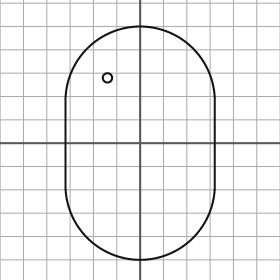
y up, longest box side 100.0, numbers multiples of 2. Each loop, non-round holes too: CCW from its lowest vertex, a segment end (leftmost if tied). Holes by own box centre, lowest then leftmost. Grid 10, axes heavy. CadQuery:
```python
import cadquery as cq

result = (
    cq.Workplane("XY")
    .moveTo(-32.0, -18.0)
    .threePointArc((0.0, -50.0), (32.0, -18.0))
    .lineTo(32.0, 18.0)
    .threePointArc((0.0, 50.0), (-32.0, 18.0))
    .close()
    .moveTo(-14.0, 28.0)
    .circle(2.0)
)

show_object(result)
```